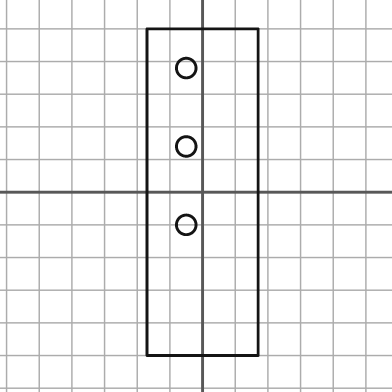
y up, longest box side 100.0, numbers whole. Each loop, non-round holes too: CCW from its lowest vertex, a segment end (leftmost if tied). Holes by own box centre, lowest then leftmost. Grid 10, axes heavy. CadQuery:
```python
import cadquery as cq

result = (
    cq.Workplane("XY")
    .moveTo(-17.0, -50.0)
    .lineTo(17.0, -50.0)
    .lineTo(17.0, 50.0)
    .lineTo(-17.0, 50.0)
    .close()
    .moveTo(-5.0, -10.0)
    .circle(3.0)
    .moveTo(-5.0, 14.0)
    .circle(3.0)
    .moveTo(-5.0, 38.0)
    .circle(3.0)
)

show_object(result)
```